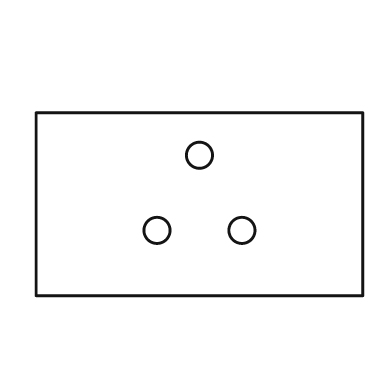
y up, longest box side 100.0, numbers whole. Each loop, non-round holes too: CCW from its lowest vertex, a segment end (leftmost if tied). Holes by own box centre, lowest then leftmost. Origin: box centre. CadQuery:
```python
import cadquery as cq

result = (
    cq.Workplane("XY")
    .moveTo(-50.0, -28.0)
    .lineTo(50.0, -28.0)
    .lineTo(50.0, 28.0)
    .lineTo(-50.0, 28.0)
    .close()
    .moveTo(-13.0, -8.0)
    .circle(4.0)
    .moveTo(13.0, -8.0)
    .circle(4.0)
    .moveTo(0.0, 15.0)
    .circle(4.0)
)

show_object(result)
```